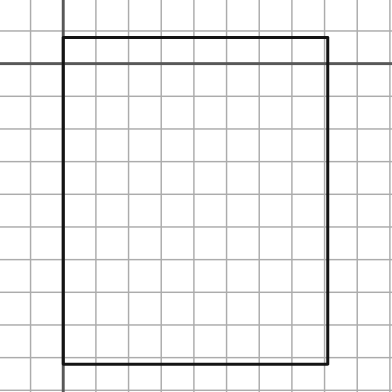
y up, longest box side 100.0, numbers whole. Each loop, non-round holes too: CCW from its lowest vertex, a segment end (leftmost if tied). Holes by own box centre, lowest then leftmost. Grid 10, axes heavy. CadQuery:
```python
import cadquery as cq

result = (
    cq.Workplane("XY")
    .moveTo(0.0, -92.0)
    .lineTo(81.0, -92.0)
    .lineTo(81.0, 8.0)
    .lineTo(0.0, 8.0)
    .close()
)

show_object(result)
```